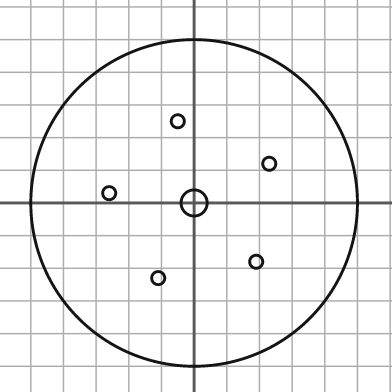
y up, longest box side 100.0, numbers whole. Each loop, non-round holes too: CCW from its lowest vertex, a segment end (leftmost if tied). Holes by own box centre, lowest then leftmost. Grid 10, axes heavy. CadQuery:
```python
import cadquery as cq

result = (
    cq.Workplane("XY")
    .moveTo(0.0, 0.0)
    .circle(50.0)
    .moveTo(-11.0, -23.0)
    .circle(2.0)
    .moveTo(19.0, -18.0)
    .circle(2.0)
    .moveTo(0.0, 0.0)
    .circle(4.0)
    .moveTo(-26.0, 3.0)
    .circle(2.0)
    .moveTo(23.0, 12.0)
    .circle(2.0)
    .moveTo(-5.0, 25.0)
    .circle(2.0)
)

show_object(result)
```